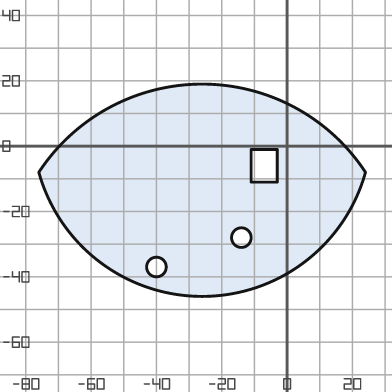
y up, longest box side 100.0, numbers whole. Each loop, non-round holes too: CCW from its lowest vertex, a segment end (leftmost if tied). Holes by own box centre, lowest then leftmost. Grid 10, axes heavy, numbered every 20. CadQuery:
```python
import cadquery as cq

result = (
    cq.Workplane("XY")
    .moveTo(-76.0, -8.0)
    .threePointArc((-26.0, -46.0), (24.0, -8.0))
    .threePointArc((-26.0, 19.0), (-76.0, -8.0))
    .close()
    .moveTo(-40.0, -37.0)
    .circle(3.0)
    .moveTo(-14.0, -28.0)
    .circle(3.0)
    .moveTo(-11.0, -11.0)
    .lineTo(-3.0, -11.0)
    .lineTo(-3.0, -1.0)
    .lineTo(-11.0, -1.0)
    .close()
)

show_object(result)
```